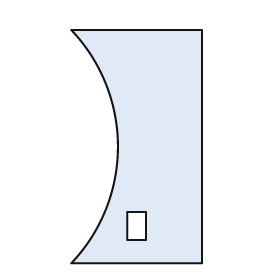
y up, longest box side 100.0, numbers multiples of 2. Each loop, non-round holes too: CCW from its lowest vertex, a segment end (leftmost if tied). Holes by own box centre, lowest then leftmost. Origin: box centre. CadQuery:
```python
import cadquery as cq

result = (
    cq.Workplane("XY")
    .moveTo(-28.0, -50.0)
    .lineTo(28.0, -50.0)
    .lineTo(28.0, 50.0)
    .lineTo(-28.0, 50.0)
    .threePointArc((-8.0, 0.0), (-28.0, -50.0))
    .close()
    .moveTo(-4.0, -40.0)
    .lineTo(4.0, -40.0)
    .lineTo(4.0, -28.0)
    .lineTo(-4.0, -28.0)
    .close()
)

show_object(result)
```